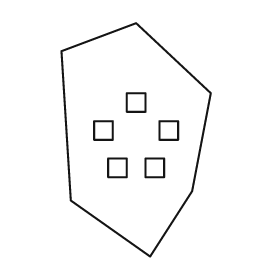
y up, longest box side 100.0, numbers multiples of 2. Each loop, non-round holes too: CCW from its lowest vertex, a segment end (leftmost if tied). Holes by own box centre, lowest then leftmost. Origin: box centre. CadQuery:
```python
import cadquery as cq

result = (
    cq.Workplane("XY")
    .moveTo(6.0, -50.0)
    .lineTo(24.0, -22.0)
    .lineTo(32.0, 20.0)
    .lineTo(0.0, 50.0)
    .lineTo(-32.0, 38.0)
    .lineTo(-28.0, -26.0)
    .close()
    .moveTo(-12.0, -16.0)
    .lineTo(-4.0, -16.0)
    .lineTo(-4.0, -8.0)
    .lineTo(-12.0, -8.0)
    .close()
    .moveTo(4.0, -16.0)
    .lineTo(12.0, -16.0)
    .lineTo(12.0, -8.0)
    .lineTo(4.0, -8.0)
    .close()
    .moveTo(-18.0, 0.0)
    .lineTo(-10.0, 0.0)
    .lineTo(-10.0, 8.0)
    .lineTo(-18.0, 8.0)
    .close()
    .moveTo(10.0, 0.0)
    .lineTo(18.0, 0.0)
    .lineTo(18.0, 8.0)
    .lineTo(10.0, 8.0)
    .close()
    .moveTo(-4.0, 12.0)
    .lineTo(4.0, 12.0)
    .lineTo(4.0, 20.0)
    .lineTo(-4.0, 20.0)
    .close()
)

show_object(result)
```